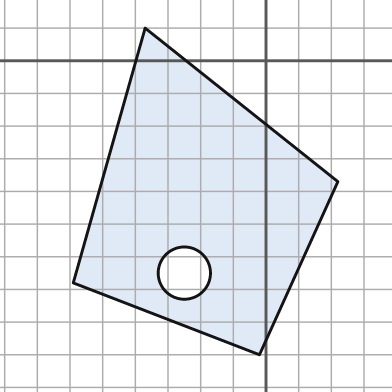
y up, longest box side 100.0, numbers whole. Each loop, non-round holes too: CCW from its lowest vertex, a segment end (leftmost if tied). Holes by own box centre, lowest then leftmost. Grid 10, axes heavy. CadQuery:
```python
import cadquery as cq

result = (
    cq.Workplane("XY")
    .moveTo(-2.0, -90.0)
    .lineTo(22.0, -37.0)
    .lineTo(-37.0, 10.0)
    .lineTo(-59.0, -68.0)
    .close()
    .moveTo(-25.0, -65.0)
    .circle(8.0)
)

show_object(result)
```